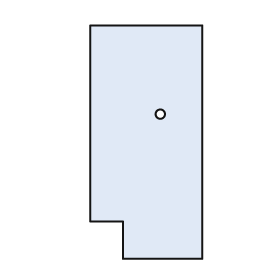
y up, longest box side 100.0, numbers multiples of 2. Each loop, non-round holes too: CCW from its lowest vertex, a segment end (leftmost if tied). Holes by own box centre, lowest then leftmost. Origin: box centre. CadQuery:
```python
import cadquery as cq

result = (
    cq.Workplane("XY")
    .moveTo(-10.0, -50.0)
    .lineTo(24.0, -50.0)
    .lineTo(24.0, 50.0)
    .lineTo(-24.0, 50.0)
    .lineTo(-24.0, -34.0)
    .lineTo(-10.0, -34.0)
    .close()
    .moveTo(6.0, 12.0)
    .circle(2.0)
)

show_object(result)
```